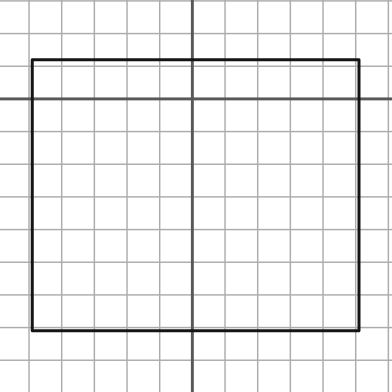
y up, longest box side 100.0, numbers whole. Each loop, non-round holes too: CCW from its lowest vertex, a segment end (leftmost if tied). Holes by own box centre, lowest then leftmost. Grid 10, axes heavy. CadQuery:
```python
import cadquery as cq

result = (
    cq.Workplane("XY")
    .moveTo(-49.0, -71.0)
    .lineTo(51.0, -71.0)
    .lineTo(51.0, 12.0)
    .lineTo(-49.0, 12.0)
    .close()
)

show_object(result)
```